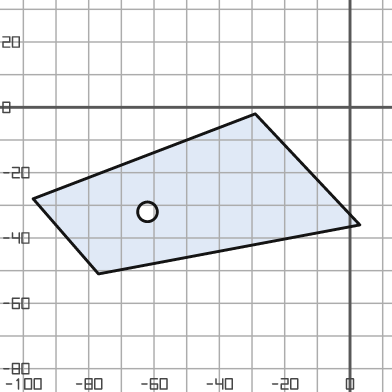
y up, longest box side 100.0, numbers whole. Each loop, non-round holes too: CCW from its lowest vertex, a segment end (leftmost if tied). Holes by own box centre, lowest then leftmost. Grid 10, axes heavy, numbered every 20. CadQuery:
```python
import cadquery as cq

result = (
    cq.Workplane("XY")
    .moveTo(-77.0, -51.0)
    .lineTo(3.0, -36.0)
    .lineTo(-29.0, -2.0)
    .lineTo(-97.0, -28.0)
    .close()
    .moveTo(-62.0, -32.0)
    .circle(3.0)
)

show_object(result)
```